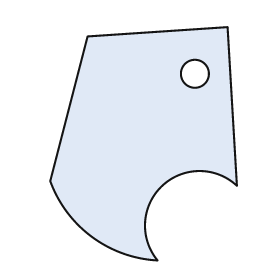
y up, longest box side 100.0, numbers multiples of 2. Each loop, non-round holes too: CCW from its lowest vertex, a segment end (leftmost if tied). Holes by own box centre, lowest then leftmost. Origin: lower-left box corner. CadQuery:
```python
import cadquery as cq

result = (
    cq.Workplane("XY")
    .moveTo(46.0, 0.0)
    .threePointArc((48.0, 32.0), (80.0, 32.0))
    .lineTo(76.0, 100.0)
    .lineTo(16.0, 96.0)
    .lineTo(0.0, 34.0)
    .threePointArc((18.0, 10.0), (46.0, 0.0))
    .close()
    .moveTo(62.0, 80.0)
    .circle(6.0)
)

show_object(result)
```